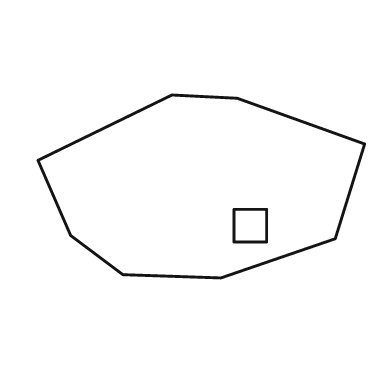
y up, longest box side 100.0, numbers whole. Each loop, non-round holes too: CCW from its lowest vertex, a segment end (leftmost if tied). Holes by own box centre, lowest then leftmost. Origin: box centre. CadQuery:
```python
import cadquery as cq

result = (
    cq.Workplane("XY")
    .moveTo(6.0, -28.0)
    .lineTo(41.0, -16.0)
    .lineTo(50.0, 13.0)
    .lineTo(11.0, 27.0)
    .lineTo(-9.0, 28.0)
    .lineTo(-50.0, 8.0)
    .lineTo(-40.0, -15.0)
    .lineTo(-24.0, -27.0)
    .close()
    .moveTo(10.0, -17.0)
    .lineTo(20.0, -17.0)
    .lineTo(20.0, -7.0)
    .lineTo(10.0, -7.0)
    .close()
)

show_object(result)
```